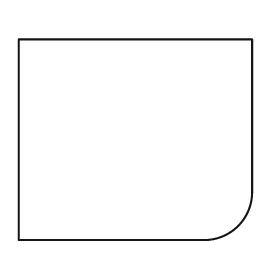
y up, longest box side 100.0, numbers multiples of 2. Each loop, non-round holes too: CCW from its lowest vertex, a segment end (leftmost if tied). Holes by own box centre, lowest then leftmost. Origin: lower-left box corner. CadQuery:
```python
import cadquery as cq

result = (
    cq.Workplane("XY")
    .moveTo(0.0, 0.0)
    .lineTo(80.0, 0.0)
    .threePointArc((94.0, 6.0), (100.0, 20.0))
    .lineTo(100.0, 86.0)
    .lineTo(0.0, 86.0)
    .close()
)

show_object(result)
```